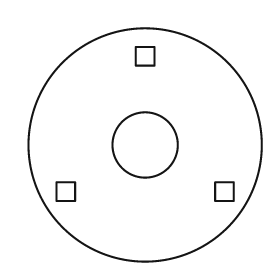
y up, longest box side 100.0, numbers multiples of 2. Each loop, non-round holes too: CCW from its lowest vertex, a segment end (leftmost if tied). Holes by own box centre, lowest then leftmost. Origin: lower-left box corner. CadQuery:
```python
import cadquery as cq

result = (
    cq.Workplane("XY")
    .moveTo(50.0, 50.0)
    .circle(50.0)
    .moveTo(12.0, 26.0)
    .lineTo(20.0, 26.0)
    .lineTo(20.0, 34.0)
    .lineTo(12.0, 34.0)
    .close()
    .moveTo(80.0, 26.0)
    .lineTo(88.0, 26.0)
    .lineTo(88.0, 34.0)
    .lineTo(80.0, 34.0)
    .close()
    .moveTo(50.0, 50.0)
    .circle(14.0)
    .moveTo(46.0, 84.0)
    .lineTo(54.0, 84.0)
    .lineTo(54.0, 92.0)
    .lineTo(46.0, 92.0)
    .close()
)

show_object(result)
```